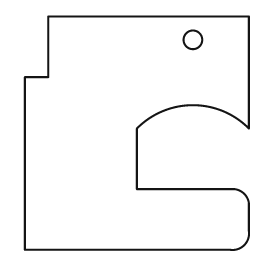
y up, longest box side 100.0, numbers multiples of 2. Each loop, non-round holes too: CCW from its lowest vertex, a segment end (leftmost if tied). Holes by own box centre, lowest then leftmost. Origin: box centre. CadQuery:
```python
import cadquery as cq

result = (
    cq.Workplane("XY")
    .moveTo(-48.0, -50.0)
    .lineTo(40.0, -50.0)
    .threePointArc((46.0, -48.0), (48.0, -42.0))
    .lineTo(48.0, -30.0)
    .threePointArc((46.0, -26.0), (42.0, -24.0))
    .lineTo(0.0, -24.0)
    .lineTo(0.0, 2.0)
    .threePointArc((24.0, 12.0), (48.0, 2.0))
    .lineTo(48.0, 50.0)
    .lineTo(-38.0, 50.0)
    .lineTo(-38.0, 24.0)
    .lineTo(-48.0, 24.0)
    .close()
    .moveTo(24.0, 40.0)
    .circle(4.0)
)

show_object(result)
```